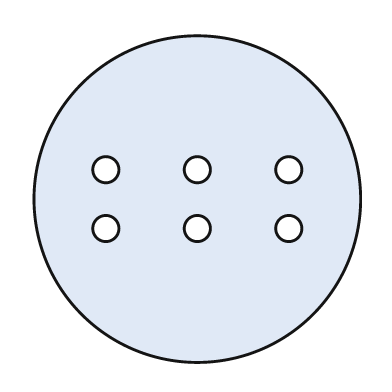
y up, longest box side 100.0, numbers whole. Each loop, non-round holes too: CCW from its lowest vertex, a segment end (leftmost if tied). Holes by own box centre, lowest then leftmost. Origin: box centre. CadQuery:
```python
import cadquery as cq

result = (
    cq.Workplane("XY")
    .moveTo(0.0, 0.0)
    .circle(50.0)
    .moveTo(-28.0, -9.0)
    .circle(4.0)
    .moveTo(0.0, -9.0)
    .circle(4.0)
    .moveTo(28.0, -9.0)
    .circle(4.0)
    .moveTo(-28.0, 9.0)
    .circle(4.0)
    .moveTo(0.0, 9.0)
    .circle(4.0)
    .moveTo(28.0, 9.0)
    .circle(4.0)
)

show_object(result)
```